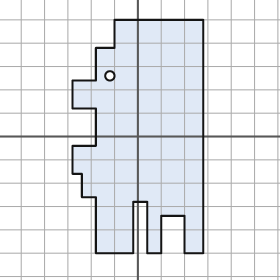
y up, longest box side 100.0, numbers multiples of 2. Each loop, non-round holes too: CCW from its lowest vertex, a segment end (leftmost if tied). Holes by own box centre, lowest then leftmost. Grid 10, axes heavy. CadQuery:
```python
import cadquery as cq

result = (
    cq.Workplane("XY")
    .moveTo(-18.0, -50.0)
    .lineTo(-2.0, -50.0)
    .lineTo(-2.0, -28.0)
    .lineTo(4.0, -28.0)
    .lineTo(4.0, -50.0)
    .lineTo(10.0, -50.0)
    .lineTo(10.0, -34.0)
    .lineTo(20.0, -34.0)
    .lineTo(20.0, -50.0)
    .lineTo(28.0, -50.0)
    .lineTo(28.0, 50.0)
    .lineTo(-10.0, 50.0)
    .lineTo(-10.0, 38.0)
    .lineTo(-18.0, 38.0)
    .lineTo(-18.0, 24.0)
    .lineTo(-28.0, 24.0)
    .lineTo(-28.0, 12.0)
    .lineTo(-18.0, 12.0)
    .lineTo(-18.0, -4.0)
    .lineTo(-28.0, -4.0)
    .lineTo(-28.0, -16.0)
    .lineTo(-24.0, -16.0)
    .lineTo(-24.0, -26.0)
    .lineTo(-18.0, -26.0)
    .close()
    .moveTo(-12.0, 26.0)
    .circle(2.0)
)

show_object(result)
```